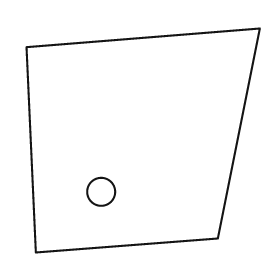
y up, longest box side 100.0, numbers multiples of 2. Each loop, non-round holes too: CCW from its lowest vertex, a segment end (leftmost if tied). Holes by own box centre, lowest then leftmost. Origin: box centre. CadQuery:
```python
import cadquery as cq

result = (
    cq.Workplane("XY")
    .moveTo(-46.0, -48.0)
    .lineTo(32.0, -42.0)
    .lineTo(50.0, 48.0)
    .lineTo(-50.0, 40.0)
    .close()
    .moveTo(-18.0, -22.0)
    .circle(6.0)
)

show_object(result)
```